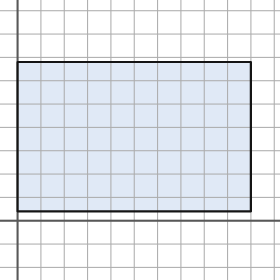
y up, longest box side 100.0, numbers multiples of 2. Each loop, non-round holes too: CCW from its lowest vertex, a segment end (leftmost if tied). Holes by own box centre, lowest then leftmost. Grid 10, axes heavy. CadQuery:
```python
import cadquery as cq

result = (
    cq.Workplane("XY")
    .moveTo(0.0, 4.0)
    .lineTo(100.0, 4.0)
    .lineTo(100.0, 68.0)
    .lineTo(0.0, 68.0)
    .close()
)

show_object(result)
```